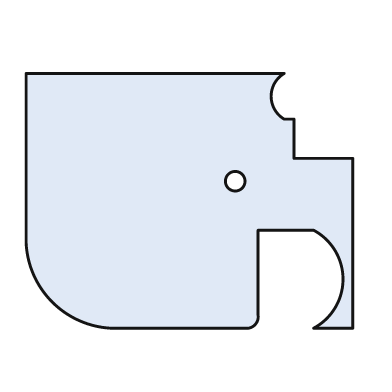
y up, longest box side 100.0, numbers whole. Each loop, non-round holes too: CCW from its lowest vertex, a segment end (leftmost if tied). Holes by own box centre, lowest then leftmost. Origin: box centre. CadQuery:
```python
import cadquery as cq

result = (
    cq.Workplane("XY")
    .moveTo(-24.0, -39.0)
    .lineTo(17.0, -39.0)
    .threePointArc((20.0, -38.0), (21.0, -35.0))
    .lineTo(21.0, -9.0)
    .lineTo(38.0, -9.0)
    .threePointArc((47.0, -24.0), (38.0, -39.0))
    .lineTo(50.0, -39.0)
    .lineTo(50.0, 13.0)
    .lineTo(32.0, 13.0)
    .lineTo(32.0, 25.0)
    .lineTo(29.0, 25.0)
    .threePointArc((25.0, 32.0), (29.0, 39.0))
    .lineTo(-50.0, 39.0)
    .lineTo(-50.0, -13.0)
    .threePointArc((-42.0, -31.0), (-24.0, -39.0))
    .close()
    .moveTo(14.0, 6.0)
    .circle(3.0)
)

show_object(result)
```